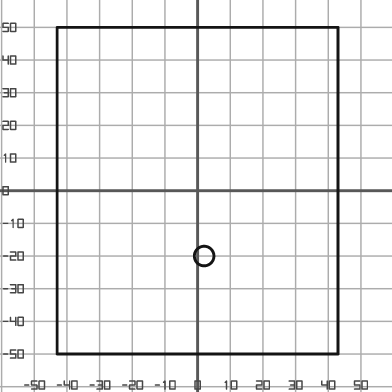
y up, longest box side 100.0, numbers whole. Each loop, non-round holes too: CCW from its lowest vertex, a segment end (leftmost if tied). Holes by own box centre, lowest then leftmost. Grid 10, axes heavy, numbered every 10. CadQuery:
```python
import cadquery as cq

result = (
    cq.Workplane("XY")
    .moveTo(-43.0, -50.0)
    .lineTo(43.0, -50.0)
    .lineTo(43.0, 50.0)
    .lineTo(-43.0, 50.0)
    .close()
    .moveTo(2.0, -20.0)
    .circle(3.0)
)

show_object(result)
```